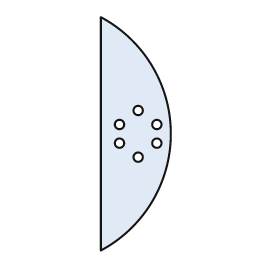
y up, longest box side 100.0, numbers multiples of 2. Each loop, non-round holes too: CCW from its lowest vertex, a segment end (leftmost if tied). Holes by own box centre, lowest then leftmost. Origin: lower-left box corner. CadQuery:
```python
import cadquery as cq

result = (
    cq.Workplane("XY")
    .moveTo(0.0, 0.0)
    .threePointArc((30.0, 50.0), (0.0, 100.0))
    .close()
    .moveTo(16.0, 40.0)
    .circle(2.0)
    .moveTo(8.0, 46.0)
    .circle(2.0)
    .moveTo(24.0, 46.0)
    .circle(2.0)
    .moveTo(8.0, 54.0)
    .circle(2.0)
    .moveTo(24.0, 54.0)
    .circle(2.0)
    .moveTo(16.0, 60.0)
    .circle(2.0)
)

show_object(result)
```